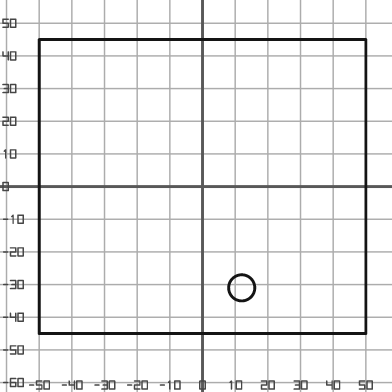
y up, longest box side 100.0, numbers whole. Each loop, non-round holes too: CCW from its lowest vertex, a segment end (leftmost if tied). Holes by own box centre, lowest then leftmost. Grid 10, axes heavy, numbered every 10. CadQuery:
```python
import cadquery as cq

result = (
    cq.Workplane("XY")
    .moveTo(-50.0, -45.0)
    .lineTo(50.0, -45.0)
    .lineTo(50.0, 45.0)
    .lineTo(-50.0, 45.0)
    .close()
    .moveTo(12.0, -31.0)
    .circle(4.0)
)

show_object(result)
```